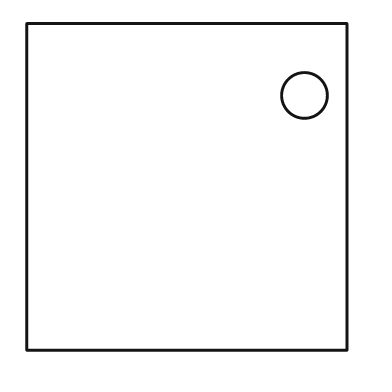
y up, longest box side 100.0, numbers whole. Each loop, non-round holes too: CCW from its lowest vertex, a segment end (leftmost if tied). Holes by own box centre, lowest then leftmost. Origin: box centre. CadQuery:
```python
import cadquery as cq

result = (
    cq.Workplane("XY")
    .moveTo(-49.0, -50.0)
    .lineTo(49.0, -50.0)
    .lineTo(49.0, 50.0)
    .lineTo(-49.0, 50.0)
    .close()
    .moveTo(36.0, 28.0)
    .circle(7.0)
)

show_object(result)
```